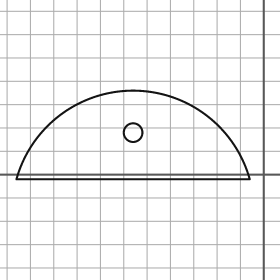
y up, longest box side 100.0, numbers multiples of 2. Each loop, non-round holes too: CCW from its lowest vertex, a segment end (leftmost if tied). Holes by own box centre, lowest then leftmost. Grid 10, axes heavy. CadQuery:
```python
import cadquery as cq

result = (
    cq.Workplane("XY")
    .moveTo(-106.0, -2.0)
    .lineTo(-6.0, -2.0)
    .threePointArc((-56.0, 36.0), (-106.0, -2.0))
    .close()
    .moveTo(-56.0, 18.0)
    .circle(4.0)
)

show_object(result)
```